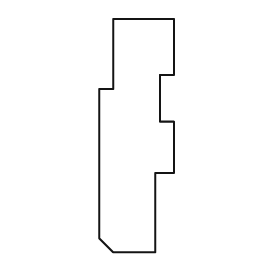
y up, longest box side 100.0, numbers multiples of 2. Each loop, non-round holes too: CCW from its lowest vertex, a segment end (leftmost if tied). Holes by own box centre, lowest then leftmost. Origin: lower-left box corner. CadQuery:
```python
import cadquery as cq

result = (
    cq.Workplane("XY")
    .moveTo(6.0, 0.0)
    .lineTo(24.0, 0.0)
    .lineTo(24.0, 34.0)
    .lineTo(32.0, 34.0)
    .lineTo(32.0, 56.0)
    .lineTo(26.0, 56.0)
    .lineTo(26.0, 76.0)
    .lineTo(32.0, 76.0)
    .lineTo(32.0, 100.0)
    .lineTo(6.0, 100.0)
    .lineTo(6.0, 70.0)
    .lineTo(0.0, 70.0)
    .lineTo(0.0, 6.0)
    .close()
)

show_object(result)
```